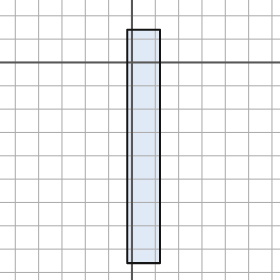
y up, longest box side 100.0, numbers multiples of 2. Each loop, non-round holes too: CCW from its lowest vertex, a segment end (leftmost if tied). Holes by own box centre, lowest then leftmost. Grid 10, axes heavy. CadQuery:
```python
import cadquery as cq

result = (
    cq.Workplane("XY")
    .moveTo(-2.0, -86.0)
    .lineTo(12.0, -86.0)
    .lineTo(12.0, 14.0)
    .lineTo(-2.0, 14.0)
    .close()
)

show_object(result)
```